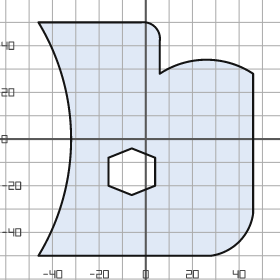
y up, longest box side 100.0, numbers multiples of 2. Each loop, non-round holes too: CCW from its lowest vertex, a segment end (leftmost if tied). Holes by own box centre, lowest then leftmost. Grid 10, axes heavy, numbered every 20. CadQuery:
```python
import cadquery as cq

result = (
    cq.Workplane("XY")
    .moveTo(-46.0, -50.0)
    .lineTo(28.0, -50.0)
    .threePointArc((40.0, -44.0), (46.0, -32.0))
    .lineTo(46.0, 28.0)
    .threePointArc((26.0, 34.0), (6.0, 28.0))
    .lineTo(6.0, 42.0)
    .threePointArc((4.0, 48.0), (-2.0, 50.0))
    .lineTo(-46.0, 50.0)
    .threePointArc((-32.0, 0.0), (-46.0, -50.0))
    .close()
    .moveTo(-6.0, -24.0)
    .lineTo(4.0, -20.0)
    .lineTo(4.0, -8.0)
    .lineTo(-6.0, -4.0)
    .lineTo(-16.0, -8.0)
    .lineTo(-16.0, -20.0)
    .close()
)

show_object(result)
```